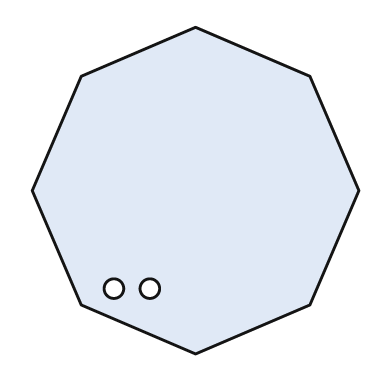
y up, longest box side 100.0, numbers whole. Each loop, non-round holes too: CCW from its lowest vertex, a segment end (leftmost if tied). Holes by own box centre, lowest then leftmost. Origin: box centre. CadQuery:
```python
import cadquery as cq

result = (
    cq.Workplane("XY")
    .moveTo(0.0, -50.0)
    .lineTo(35.0, -35.0)
    .lineTo(50.0, 0.0)
    .lineTo(35.0, 35.0)
    .lineTo(0.0, 50.0)
    .lineTo(-35.0, 35.0)
    .lineTo(-50.0, 0.0)
    .lineTo(-35.0, -35.0)
    .close()
    .moveTo(-25.0, -30.0)
    .circle(3.0)
    .moveTo(-14.0, -30.0)
    .circle(3.0)
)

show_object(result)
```